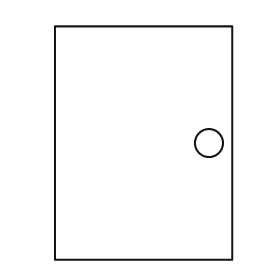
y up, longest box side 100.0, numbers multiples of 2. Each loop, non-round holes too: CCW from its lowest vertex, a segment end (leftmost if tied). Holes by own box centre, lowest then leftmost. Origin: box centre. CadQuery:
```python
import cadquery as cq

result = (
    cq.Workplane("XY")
    .moveTo(-38.0, -50.0)
    .lineTo(38.0, -50.0)
    .lineTo(38.0, 50.0)
    .lineTo(-38.0, 50.0)
    .close()
    .moveTo(28.0, 0.0)
    .circle(6.0)
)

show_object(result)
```